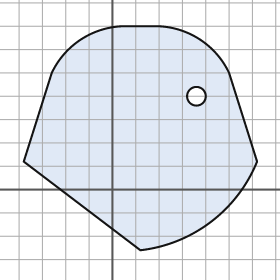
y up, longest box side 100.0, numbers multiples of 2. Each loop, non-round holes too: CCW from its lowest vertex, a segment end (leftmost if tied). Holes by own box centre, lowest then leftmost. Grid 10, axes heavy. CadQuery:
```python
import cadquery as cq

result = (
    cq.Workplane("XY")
    .moveTo(12.0, -26.0)
    .threePointArc((42.0, -14.0), (62.0, 12.0))
    .lineTo(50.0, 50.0)
    .threePointArc((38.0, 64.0), (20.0, 70.0))
    .lineTo(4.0, 70.0)
    .threePointArc((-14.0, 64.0), (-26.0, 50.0))
    .lineTo(-38.0, 12.0)
    .close()
    .moveTo(36.0, 40.0)
    .circle(4.0)
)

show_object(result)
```